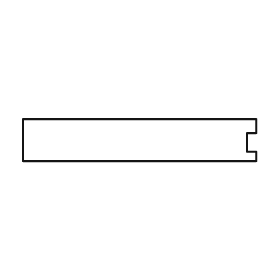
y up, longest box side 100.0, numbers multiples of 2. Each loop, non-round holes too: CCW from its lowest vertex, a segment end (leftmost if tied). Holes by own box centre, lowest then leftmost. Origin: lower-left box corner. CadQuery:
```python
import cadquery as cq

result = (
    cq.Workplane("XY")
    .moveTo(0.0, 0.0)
    .lineTo(100.0, 0.0)
    .lineTo(100.0, 4.0)
    .lineTo(96.0, 4.0)
    .lineTo(96.0, 12.0)
    .lineTo(100.0, 12.0)
    .lineTo(100.0, 18.0)
    .lineTo(0.0, 18.0)
    .close()
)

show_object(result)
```